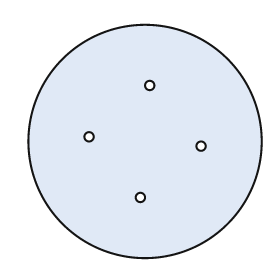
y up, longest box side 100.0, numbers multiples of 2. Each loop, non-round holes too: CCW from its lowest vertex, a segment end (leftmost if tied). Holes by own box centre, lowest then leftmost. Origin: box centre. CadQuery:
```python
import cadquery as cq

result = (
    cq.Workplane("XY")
    .moveTo(0.0, 0.0)
    .circle(50.0)
    .moveTo(-2.0, -24.0)
    .circle(2.0)
    .moveTo(24.0, -2.0)
    .circle(2.0)
    .moveTo(-24.0, 2.0)
    .circle(2.0)
    .moveTo(2.0, 24.0)
    .circle(2.0)
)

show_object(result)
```